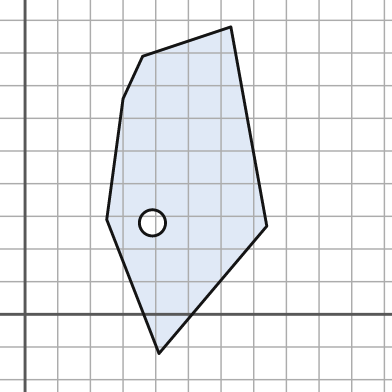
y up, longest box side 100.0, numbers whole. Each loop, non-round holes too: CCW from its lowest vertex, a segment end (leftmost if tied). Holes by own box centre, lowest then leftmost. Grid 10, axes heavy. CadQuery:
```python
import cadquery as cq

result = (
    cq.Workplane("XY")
    .moveTo(41.0, -12.0)
    .lineTo(74.0, 27.0)
    .lineTo(63.0, 88.0)
    .lineTo(36.0, 79.0)
    .lineTo(30.0, 66.0)
    .lineTo(25.0, 29.0)
    .close()
    .moveTo(39.0, 28.0)
    .circle(4.0)
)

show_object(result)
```